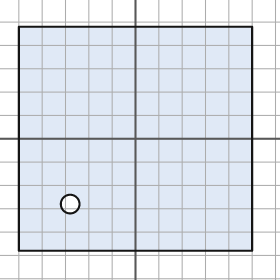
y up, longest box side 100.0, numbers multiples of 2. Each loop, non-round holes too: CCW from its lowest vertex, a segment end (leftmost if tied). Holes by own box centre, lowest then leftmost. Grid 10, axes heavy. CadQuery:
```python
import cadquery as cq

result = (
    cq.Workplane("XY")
    .moveTo(-50.0, -48.0)
    .lineTo(50.0, -48.0)
    .lineTo(50.0, 48.0)
    .lineTo(-50.0, 48.0)
    .close()
    .moveTo(-28.0, -28.0)
    .circle(4.0)
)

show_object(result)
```